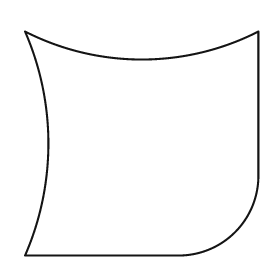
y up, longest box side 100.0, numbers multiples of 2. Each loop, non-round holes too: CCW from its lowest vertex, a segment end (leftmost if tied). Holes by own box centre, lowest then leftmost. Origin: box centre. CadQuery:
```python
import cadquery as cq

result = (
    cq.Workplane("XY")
    .moveTo(-50.0, -48.0)
    .lineTo(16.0, -48.0)
    .threePointArc((40.0, -38.0), (50.0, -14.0))
    .lineTo(50.0, 48.0)
    .threePointArc((0.0, 36.0), (-50.0, 48.0))
    .threePointArc((-40.0, 0.0), (-50.0, -48.0))
    .close()
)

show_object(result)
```